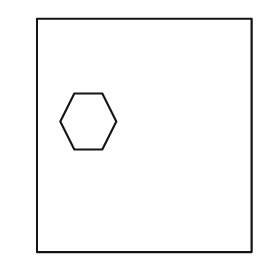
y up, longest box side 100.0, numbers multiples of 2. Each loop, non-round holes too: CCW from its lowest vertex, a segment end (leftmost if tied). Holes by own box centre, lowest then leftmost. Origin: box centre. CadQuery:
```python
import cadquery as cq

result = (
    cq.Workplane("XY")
    .moveTo(-46.0, -50.0)
    .lineTo(46.0, -50.0)
    .lineTo(46.0, 50.0)
    .lineTo(-46.0, 50.0)
    .close()
    .moveTo(-30.0, -6.0)
    .lineTo(-18.0, -6.0)
    .lineTo(-12.0, 6.0)
    .lineTo(-18.0, 18.0)
    .lineTo(-30.0, 18.0)
    .lineTo(-36.0, 6.0)
    .close()
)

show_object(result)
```